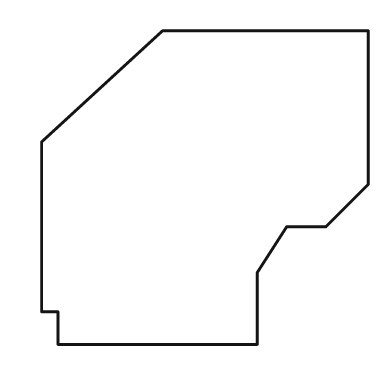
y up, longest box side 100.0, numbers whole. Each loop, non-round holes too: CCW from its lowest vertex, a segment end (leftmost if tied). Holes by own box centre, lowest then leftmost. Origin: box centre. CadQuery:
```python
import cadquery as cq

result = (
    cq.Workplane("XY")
    .moveTo(-45.0, -48.0)
    .lineTo(16.0, -48.0)
    .lineTo(16.0, -26.0)
    .lineTo(25.0, -12.0)
    .lineTo(37.0, -12.0)
    .lineTo(50.0, 1.0)
    .lineTo(50.0, 48.0)
    .lineTo(-13.0, 48.0)
    .lineTo(-50.0, 14.0)
    .lineTo(-50.0, -38.0)
    .lineTo(-45.0, -38.0)
    .close()
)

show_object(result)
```